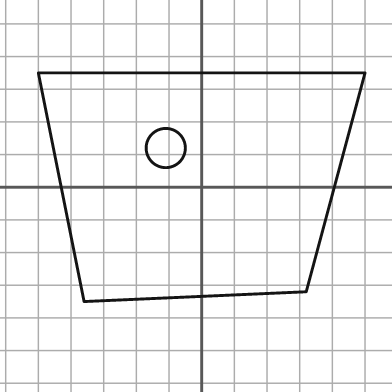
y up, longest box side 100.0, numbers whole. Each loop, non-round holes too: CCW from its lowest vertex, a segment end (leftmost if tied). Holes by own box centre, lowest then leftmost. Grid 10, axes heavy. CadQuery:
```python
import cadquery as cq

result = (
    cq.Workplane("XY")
    .moveTo(-36.0, -35.0)
    .lineTo(32.0, -32.0)
    .lineTo(50.0, 35.0)
    .lineTo(-50.0, 35.0)
    .close()
    .moveTo(-11.0, 12.0)
    .circle(6.0)
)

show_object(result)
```